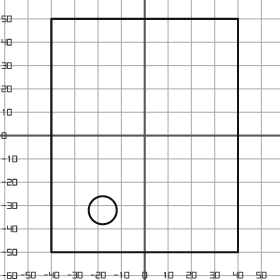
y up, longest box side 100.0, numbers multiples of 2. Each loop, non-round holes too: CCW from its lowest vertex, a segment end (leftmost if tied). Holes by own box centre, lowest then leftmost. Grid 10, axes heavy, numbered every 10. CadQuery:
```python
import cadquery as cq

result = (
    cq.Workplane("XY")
    .moveTo(-40.0, -50.0)
    .lineTo(40.0, -50.0)
    .lineTo(40.0, 50.0)
    .lineTo(-40.0, 50.0)
    .close()
    .moveTo(-18.0, -32.0)
    .circle(6.0)
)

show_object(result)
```